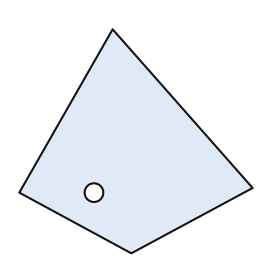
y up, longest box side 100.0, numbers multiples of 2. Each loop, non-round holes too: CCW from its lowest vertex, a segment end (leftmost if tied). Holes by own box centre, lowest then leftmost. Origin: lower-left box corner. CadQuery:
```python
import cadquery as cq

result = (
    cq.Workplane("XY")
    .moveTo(48.0, 0.0)
    .lineTo(100.0, 28.0)
    .lineTo(40.0, 96.0)
    .lineTo(0.0, 26.0)
    .close()
    .moveTo(32.0, 26.0)
    .circle(4.0)
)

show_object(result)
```